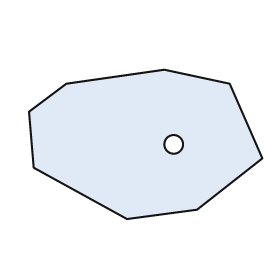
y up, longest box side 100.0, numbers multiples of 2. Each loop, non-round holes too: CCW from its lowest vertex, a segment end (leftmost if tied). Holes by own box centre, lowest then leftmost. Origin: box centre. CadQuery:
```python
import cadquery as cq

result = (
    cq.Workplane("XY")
    .moveTo(-8.0, -32.0)
    .lineTo(22.0, -28.0)
    .lineTo(50.0, -6.0)
    .lineTo(36.0, 26.0)
    .lineTo(8.0, 32.0)
    .lineTo(-34.0, 26.0)
    .lineTo(-50.0, 14.0)
    .lineTo(-48.0, -10.0)
    .close()
    .moveTo(12.0, 0.0)
    .circle(4.0)
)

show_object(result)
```